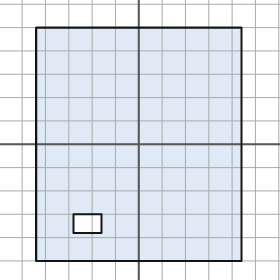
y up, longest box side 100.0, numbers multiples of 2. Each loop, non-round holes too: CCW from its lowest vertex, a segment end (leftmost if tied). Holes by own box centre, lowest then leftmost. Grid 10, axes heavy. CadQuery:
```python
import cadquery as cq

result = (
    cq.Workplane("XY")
    .moveTo(-44.0, -50.0)
    .lineTo(44.0, -50.0)
    .lineTo(44.0, 50.0)
    .lineTo(-44.0, 50.0)
    .close()
    .moveTo(-28.0, -38.0)
    .lineTo(-16.0, -38.0)
    .lineTo(-16.0, -30.0)
    .lineTo(-28.0, -30.0)
    .close()
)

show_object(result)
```